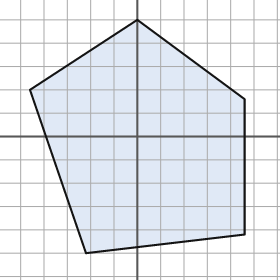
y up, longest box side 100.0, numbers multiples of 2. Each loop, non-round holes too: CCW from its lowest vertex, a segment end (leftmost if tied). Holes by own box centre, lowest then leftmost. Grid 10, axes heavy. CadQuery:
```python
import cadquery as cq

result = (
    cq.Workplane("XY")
    .moveTo(-22.0, -50.0)
    .lineTo(46.0, -42.0)
    .lineTo(46.0, 16.0)
    .lineTo(0.0, 50.0)
    .lineTo(-46.0, 20.0)
    .close()
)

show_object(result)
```